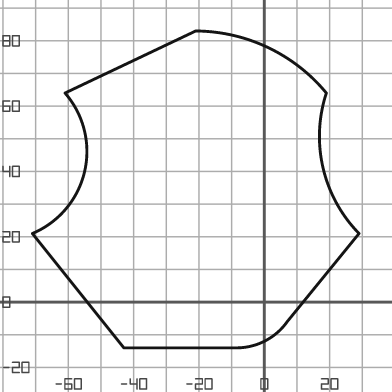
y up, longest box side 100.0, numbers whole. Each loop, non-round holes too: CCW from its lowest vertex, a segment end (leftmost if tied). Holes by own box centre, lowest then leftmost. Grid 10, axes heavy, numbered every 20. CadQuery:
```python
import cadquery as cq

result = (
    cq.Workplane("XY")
    .moveTo(-43.0, -14.0)
    .lineTo(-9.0, -14.0)
    .threePointArc((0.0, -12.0), (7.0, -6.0))
    .lineTo(29.0, 21.0)
    .threePointArc((18.0, 41.0), (19.0, 64.0))
    .threePointArc((1.0, 78.0), (-21.0, 83.0))
    .lineTo(-61.0, 64.0)
    .threePointArc((-55.0, 40.0), (-71.0, 21.0))
    .close()
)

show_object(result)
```